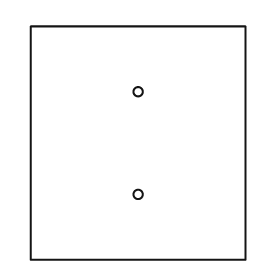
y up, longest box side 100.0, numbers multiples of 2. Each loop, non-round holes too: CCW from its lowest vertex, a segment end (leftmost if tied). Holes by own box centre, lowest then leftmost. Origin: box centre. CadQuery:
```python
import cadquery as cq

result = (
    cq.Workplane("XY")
    .moveTo(-46.0, -50.0)
    .lineTo(46.0, -50.0)
    .lineTo(46.0, 50.0)
    .lineTo(-46.0, 50.0)
    .close()
    .moveTo(0.0, -22.0)
    .circle(2.0)
    .moveTo(0.0, 22.0)
    .circle(2.0)
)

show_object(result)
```